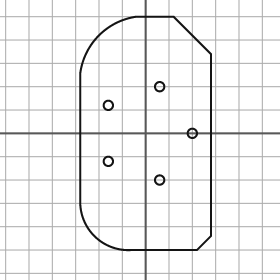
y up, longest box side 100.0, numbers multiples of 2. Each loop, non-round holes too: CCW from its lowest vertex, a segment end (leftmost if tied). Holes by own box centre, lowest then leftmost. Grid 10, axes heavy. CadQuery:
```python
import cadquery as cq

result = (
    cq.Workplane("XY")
    .moveTo(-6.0, -50.0)
    .lineTo(22.0, -50.0)
    .lineTo(28.0, -44.0)
    .lineTo(28.0, 34.0)
    .lineTo(12.0, 50.0)
    .lineTo(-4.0, 50.0)
    .threePointArc((-20.0, 42.0), (-28.0, 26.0))
    .lineTo(-28.0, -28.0)
    .threePointArc((-22.0, -44.0), (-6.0, -50.0))
    .close()
    .moveTo(6.0, -20.0)
    .circle(2.0)
    .moveTo(-16.0, -12.0)
    .circle(2.0)
    .moveTo(20.0, 0.0)
    .circle(2.0)
    .moveTo(-16.0, 12.0)
    .circle(2.0)
    .moveTo(6.0, 20.0)
    .circle(2.0)
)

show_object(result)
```